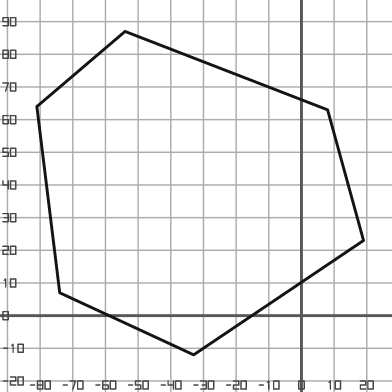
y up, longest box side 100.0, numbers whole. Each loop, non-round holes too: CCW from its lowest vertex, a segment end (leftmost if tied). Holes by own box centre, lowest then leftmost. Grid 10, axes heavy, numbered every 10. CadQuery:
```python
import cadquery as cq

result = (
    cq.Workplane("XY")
    .moveTo(-33.0, -12.0)
    .lineTo(19.0, 23.0)
    .lineTo(8.0, 63.0)
    .lineTo(-54.0, 87.0)
    .lineTo(-81.0, 64.0)
    .lineTo(-74.0, 7.0)
    .close()
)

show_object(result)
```